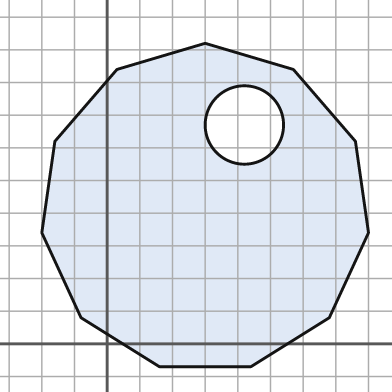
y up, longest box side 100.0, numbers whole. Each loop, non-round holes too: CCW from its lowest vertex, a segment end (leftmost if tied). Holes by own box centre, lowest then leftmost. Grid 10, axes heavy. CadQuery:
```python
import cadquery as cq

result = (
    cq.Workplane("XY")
    .moveTo(16.0, -7.0)
    .lineTo(44.0, -7.0)
    .lineTo(68.0, 8.0)
    .lineTo(80.0, 34.0)
    .lineTo(76.0, 62.0)
    .lineTo(57.0, 84.0)
    .lineTo(30.0, 92.0)
    .lineTo(3.0, 84.0)
    .lineTo(-16.0, 62.0)
    .lineTo(-20.0, 34.0)
    .lineTo(-8.0, 8.0)
    .close()
    .moveTo(42.0, 67.0)
    .circle(12.0)
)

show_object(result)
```